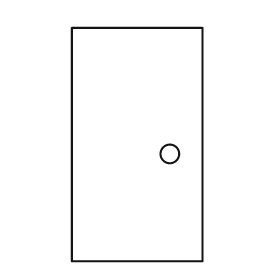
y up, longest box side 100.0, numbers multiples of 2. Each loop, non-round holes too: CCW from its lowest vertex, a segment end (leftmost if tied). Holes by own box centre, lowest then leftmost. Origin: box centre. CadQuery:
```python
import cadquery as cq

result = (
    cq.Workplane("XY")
    .moveTo(-28.0, -50.0)
    .lineTo(28.0, -50.0)
    .lineTo(28.0, 50.0)
    .lineTo(-28.0, 50.0)
    .close()
    .moveTo(14.0, -4.0)
    .circle(4.0)
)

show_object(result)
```